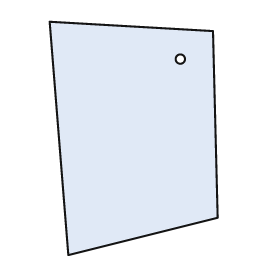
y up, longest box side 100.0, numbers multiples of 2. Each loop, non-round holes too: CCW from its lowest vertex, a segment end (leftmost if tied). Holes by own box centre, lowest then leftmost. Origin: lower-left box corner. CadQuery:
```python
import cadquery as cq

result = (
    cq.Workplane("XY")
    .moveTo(8.0, 0.0)
    .lineTo(72.0, 16.0)
    .lineTo(70.0, 96.0)
    .lineTo(0.0, 100.0)
    .close()
    .moveTo(56.0, 84.0)
    .circle(2.0)
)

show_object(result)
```